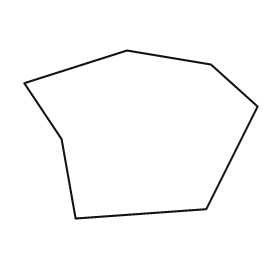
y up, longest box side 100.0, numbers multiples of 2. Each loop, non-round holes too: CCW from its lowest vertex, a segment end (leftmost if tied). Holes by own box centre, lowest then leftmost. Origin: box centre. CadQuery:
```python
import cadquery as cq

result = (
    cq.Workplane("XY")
    .moveTo(-28.0, -36.0)
    .lineTo(28.0, -32.0)
    .lineTo(50.0, 12.0)
    .lineTo(30.0, 30.0)
    .lineTo(-6.0, 36.0)
    .lineTo(-50.0, 22.0)
    .lineTo(-34.0, -2.0)
    .close()
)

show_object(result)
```